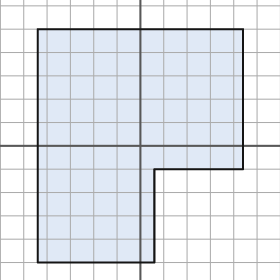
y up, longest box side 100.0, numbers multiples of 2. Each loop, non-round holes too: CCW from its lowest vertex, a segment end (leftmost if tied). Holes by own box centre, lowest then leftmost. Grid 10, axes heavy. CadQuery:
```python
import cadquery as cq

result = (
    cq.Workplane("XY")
    .moveTo(-44.0, -50.0)
    .lineTo(6.0, -50.0)
    .lineTo(6.0, -10.0)
    .lineTo(44.0, -10.0)
    .lineTo(44.0, 50.0)
    .lineTo(-44.0, 50.0)
    .close()
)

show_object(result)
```